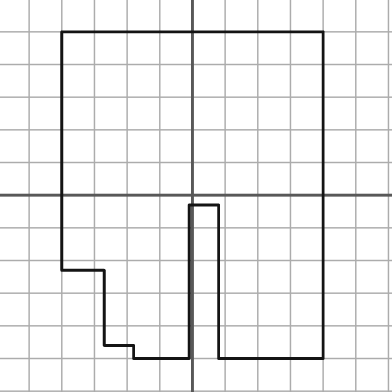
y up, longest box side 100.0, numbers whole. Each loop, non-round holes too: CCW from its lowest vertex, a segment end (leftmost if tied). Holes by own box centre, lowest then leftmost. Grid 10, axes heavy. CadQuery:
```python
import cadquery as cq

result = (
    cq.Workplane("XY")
    .moveTo(-18.0, -50.0)
    .lineTo(-1.0, -50.0)
    .lineTo(-1.0, -3.0)
    .lineTo(8.0, -3.0)
    .lineTo(8.0, -50.0)
    .lineTo(40.0, -50.0)
    .lineTo(40.0, 50.0)
    .lineTo(-40.0, 50.0)
    .lineTo(-40.0, -23.0)
    .lineTo(-27.0, -23.0)
    .lineTo(-27.0, -46.0)
    .lineTo(-18.0, -46.0)
    .close()
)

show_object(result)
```